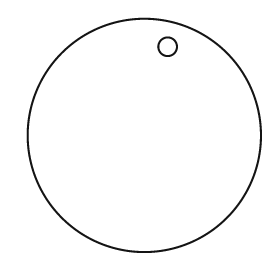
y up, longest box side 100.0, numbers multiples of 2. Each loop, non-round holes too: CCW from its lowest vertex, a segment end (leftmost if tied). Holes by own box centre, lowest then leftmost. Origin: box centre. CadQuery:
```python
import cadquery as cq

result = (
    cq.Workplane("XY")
    .moveTo(0.0, 0.0)
    .circle(50.0)
    .moveTo(10.0, 38.0)
    .circle(4.0)
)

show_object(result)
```